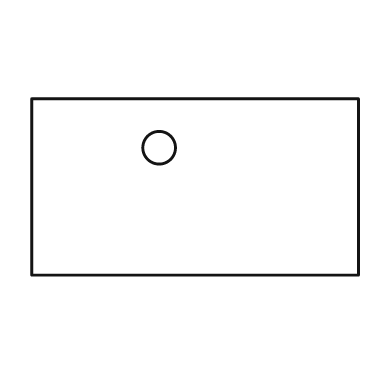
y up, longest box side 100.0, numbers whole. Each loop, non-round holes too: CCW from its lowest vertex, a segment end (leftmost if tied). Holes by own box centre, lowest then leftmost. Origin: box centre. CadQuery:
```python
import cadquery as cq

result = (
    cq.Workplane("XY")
    .moveTo(-50.0, -27.0)
    .lineTo(50.0, -27.0)
    .lineTo(50.0, 27.0)
    .lineTo(-50.0, 27.0)
    .close()
    .moveTo(-11.0, 12.0)
    .circle(5.0)
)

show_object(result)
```